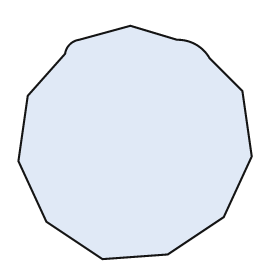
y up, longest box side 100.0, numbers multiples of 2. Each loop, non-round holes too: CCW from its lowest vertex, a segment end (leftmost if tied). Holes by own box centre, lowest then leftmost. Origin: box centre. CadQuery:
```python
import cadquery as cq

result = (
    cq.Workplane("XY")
    .moveTo(-14.0, -50.0)
    .lineTo(14.0, -48.0)
    .lineTo(38.0, -32.0)
    .lineTo(50.0, -6.0)
    .lineTo(46.0, 22.0)
    .lineTo(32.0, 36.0)
    .threePointArc((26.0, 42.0), (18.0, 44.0))
    .lineTo(-2.0, 50.0)
    .lineTo(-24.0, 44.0)
    .threePointArc((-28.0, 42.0), (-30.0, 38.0))
    .lineTo(-46.0, 20.0)
    .lineTo(-50.0, -8.0)
    .lineTo(-38.0, -34.0)
    .close()
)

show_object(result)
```